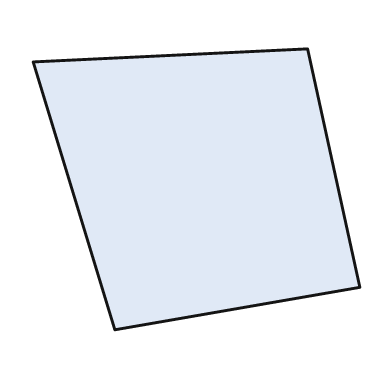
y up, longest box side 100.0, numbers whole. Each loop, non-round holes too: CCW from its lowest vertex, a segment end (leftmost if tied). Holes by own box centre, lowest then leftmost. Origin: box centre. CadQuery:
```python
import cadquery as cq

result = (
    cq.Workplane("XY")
    .moveTo(-25.0, -43.0)
    .lineTo(50.0, -30.0)
    .lineTo(34.0, 43.0)
    .lineTo(-50.0, 39.0)
    .close()
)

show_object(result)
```